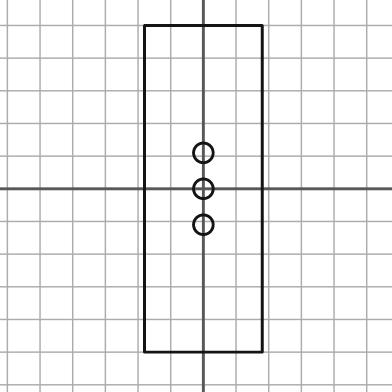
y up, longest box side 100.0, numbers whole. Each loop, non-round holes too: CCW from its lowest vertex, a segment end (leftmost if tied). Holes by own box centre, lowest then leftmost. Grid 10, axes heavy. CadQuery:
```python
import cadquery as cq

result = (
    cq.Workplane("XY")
    .moveTo(-18.0, -50.0)
    .lineTo(18.0, -50.0)
    .lineTo(18.0, 50.0)
    .lineTo(-18.0, 50.0)
    .close()
    .moveTo(0.0, -11.0)
    .circle(3.0)
    .moveTo(0.0, 0.0)
    .circle(3.0)
    .moveTo(0.0, 11.0)
    .circle(3.0)
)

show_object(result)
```